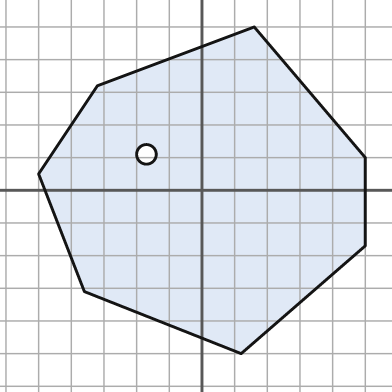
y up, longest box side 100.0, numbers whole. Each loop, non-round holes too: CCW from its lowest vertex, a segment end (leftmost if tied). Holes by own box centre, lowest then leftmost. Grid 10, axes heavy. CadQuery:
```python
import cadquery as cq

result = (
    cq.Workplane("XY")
    .moveTo(12.0, -50.0)
    .lineTo(50.0, -17.0)
    .lineTo(50.0, 10.0)
    .lineTo(16.0, 50.0)
    .lineTo(-32.0, 32.0)
    .lineTo(-50.0, 5.0)
    .lineTo(-36.0, -31.0)
    .close()
    .moveTo(-17.0, 11.0)
    .circle(3.0)
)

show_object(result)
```